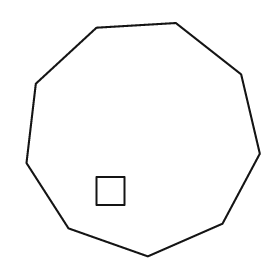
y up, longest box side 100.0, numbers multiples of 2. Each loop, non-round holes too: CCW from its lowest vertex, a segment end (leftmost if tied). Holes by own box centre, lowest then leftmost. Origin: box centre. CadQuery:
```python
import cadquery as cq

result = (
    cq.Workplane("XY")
    .moveTo(2.0, -50.0)
    .lineTo(34.0, -36.0)
    .lineTo(50.0, -6.0)
    .lineTo(42.0, 28.0)
    .lineTo(14.0, 50.0)
    .lineTo(-20.0, 48.0)
    .lineTo(-46.0, 24.0)
    .lineTo(-50.0, -10.0)
    .lineTo(-32.0, -38.0)
    .close()
    .moveTo(-20.0, -28.0)
    .lineTo(-8.0, -28.0)
    .lineTo(-8.0, -16.0)
    .lineTo(-20.0, -16.0)
    .close()
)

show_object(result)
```